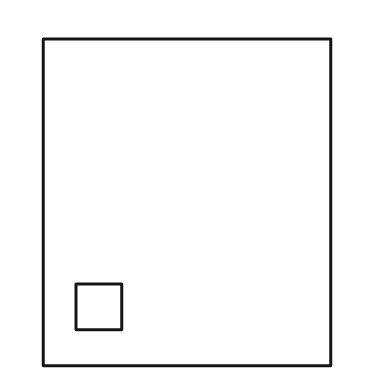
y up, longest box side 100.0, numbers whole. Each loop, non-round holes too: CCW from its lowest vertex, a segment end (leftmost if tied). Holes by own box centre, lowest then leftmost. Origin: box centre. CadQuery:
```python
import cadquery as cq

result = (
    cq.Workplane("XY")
    .moveTo(-44.0, -50.0)
    .lineTo(44.0, -50.0)
    .lineTo(44.0, 50.0)
    .lineTo(-44.0, 50.0)
    .close()
    .moveTo(-34.0, -39.0)
    .lineTo(-20.0, -39.0)
    .lineTo(-20.0, -25.0)
    .lineTo(-34.0, -25.0)
    .close()
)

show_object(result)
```